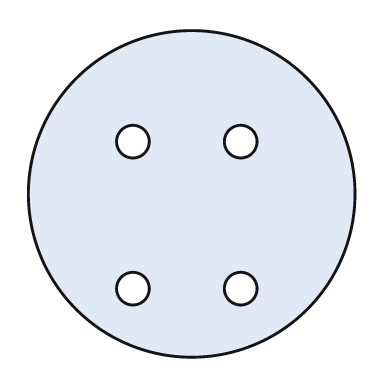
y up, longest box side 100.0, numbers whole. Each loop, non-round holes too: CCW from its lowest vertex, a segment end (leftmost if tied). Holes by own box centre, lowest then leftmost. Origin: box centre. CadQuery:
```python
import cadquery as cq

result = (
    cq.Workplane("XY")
    .moveTo(0.0, 0.0)
    .circle(50.0)
    .moveTo(-18.0, -29.0)
    .circle(5.0)
    .moveTo(15.0, -29.0)
    .circle(5.0)
    .moveTo(-18.0, 16.0)
    .circle(5.0)
    .moveTo(15.0, 16.0)
    .circle(5.0)
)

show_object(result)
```